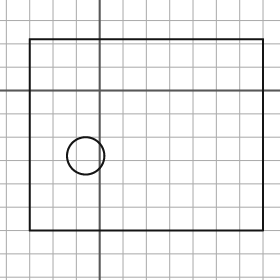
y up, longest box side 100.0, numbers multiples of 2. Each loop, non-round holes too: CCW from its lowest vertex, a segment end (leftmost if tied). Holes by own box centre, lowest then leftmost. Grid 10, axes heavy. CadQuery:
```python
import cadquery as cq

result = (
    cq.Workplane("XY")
    .moveTo(-30.0, -60.0)
    .lineTo(70.0, -60.0)
    .lineTo(70.0, 22.0)
    .lineTo(-30.0, 22.0)
    .close()
    .moveTo(-6.0, -28.0)
    .circle(8.0)
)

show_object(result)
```